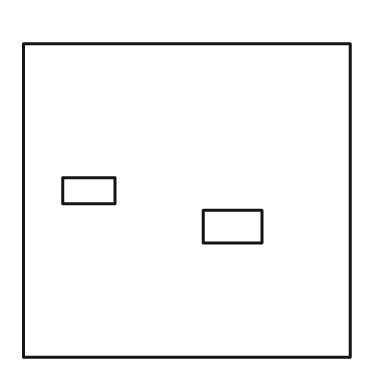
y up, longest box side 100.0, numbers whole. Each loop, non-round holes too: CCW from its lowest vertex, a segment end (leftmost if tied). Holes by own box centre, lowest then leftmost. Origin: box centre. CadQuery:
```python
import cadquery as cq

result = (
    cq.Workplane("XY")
    .moveTo(-50.0, -48.0)
    .lineTo(50.0, -48.0)
    .lineTo(50.0, 48.0)
    .lineTo(-50.0, 48.0)
    .close()
    .moveTo(5.0, -13.0)
    .lineTo(23.0, -13.0)
    .lineTo(23.0, -3.0)
    .lineTo(5.0, -3.0)
    .close()
    .moveTo(-38.0, -1.0)
    .lineTo(-22.0, -1.0)
    .lineTo(-22.0, 7.0)
    .lineTo(-38.0, 7.0)
    .close()
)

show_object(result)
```